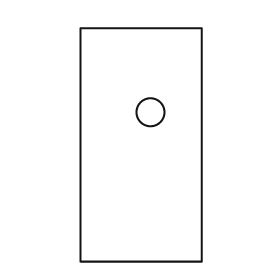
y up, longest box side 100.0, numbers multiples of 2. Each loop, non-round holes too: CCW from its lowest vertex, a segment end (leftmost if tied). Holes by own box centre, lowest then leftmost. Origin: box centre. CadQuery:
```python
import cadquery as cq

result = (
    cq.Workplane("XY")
    .moveTo(-26.0, -50.0)
    .lineTo(26.0, -50.0)
    .lineTo(26.0, 50.0)
    .lineTo(-26.0, 50.0)
    .close()
    .moveTo(4.0, 14.0)
    .circle(6.0)
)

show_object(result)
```